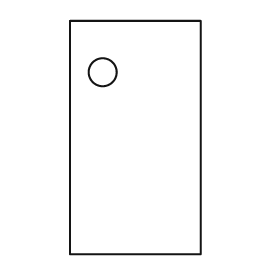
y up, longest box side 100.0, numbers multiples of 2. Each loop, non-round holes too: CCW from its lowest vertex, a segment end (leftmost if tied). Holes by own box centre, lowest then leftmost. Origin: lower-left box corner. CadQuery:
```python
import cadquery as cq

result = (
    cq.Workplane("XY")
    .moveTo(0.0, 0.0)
    .lineTo(56.0, 0.0)
    .lineTo(56.0, 100.0)
    .lineTo(0.0, 100.0)
    .close()
    .moveTo(14.0, 78.0)
    .circle(6.0)
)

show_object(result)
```